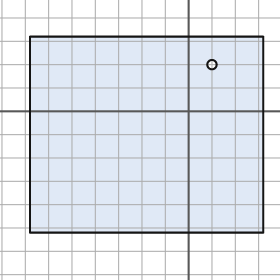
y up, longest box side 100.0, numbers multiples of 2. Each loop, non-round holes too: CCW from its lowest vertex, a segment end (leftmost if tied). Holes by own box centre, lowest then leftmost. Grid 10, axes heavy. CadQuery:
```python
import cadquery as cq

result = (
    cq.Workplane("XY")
    .moveTo(-68.0, -52.0)
    .lineTo(32.0, -52.0)
    .lineTo(32.0, 32.0)
    .lineTo(-68.0, 32.0)
    .close()
    .moveTo(10.0, 20.0)
    .circle(2.0)
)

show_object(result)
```